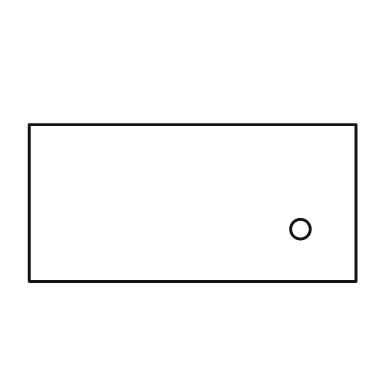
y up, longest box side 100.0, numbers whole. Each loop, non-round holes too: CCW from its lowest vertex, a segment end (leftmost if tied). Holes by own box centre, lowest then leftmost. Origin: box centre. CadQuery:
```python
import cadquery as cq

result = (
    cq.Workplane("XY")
    .moveTo(-50.0, -24.0)
    .lineTo(50.0, -24.0)
    .lineTo(50.0, 24.0)
    .lineTo(-50.0, 24.0)
    .close()
    .moveTo(33.0, -8.0)
    .circle(3.0)
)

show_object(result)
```